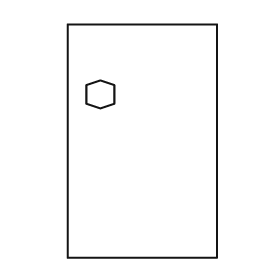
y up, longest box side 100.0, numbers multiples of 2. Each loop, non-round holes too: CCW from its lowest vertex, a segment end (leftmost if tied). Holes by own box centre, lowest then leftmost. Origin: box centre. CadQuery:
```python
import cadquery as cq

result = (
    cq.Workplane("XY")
    .moveTo(-32.0, -50.0)
    .lineTo(32.0, -50.0)
    .lineTo(32.0, 50.0)
    .lineTo(-32.0, 50.0)
    .close()
    .moveTo(-18.0, 14.0)
    .lineTo(-12.0, 16.0)
    .lineTo(-12.0, 24.0)
    .lineTo(-18.0, 26.0)
    .lineTo(-24.0, 24.0)
    .lineTo(-24.0, 16.0)
    .close()
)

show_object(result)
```